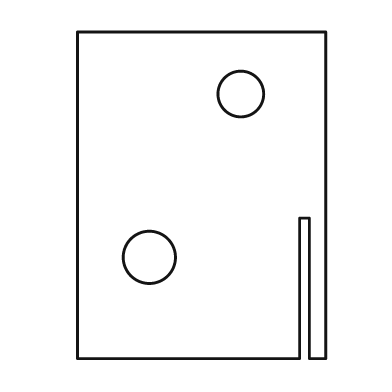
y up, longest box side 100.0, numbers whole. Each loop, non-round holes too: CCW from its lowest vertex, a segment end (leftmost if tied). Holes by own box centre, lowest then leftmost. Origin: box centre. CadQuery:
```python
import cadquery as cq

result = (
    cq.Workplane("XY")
    .moveTo(-38.0, -50.0)
    .lineTo(30.0, -50.0)
    .lineTo(30.0, -7.0)
    .lineTo(33.0, -7.0)
    .lineTo(33.0, -50.0)
    .lineTo(38.0, -50.0)
    .lineTo(38.0, 50.0)
    .lineTo(-38.0, 50.0)
    .close()
    .moveTo(-16.0, -19.0)
    .circle(8.0)
    .moveTo(12.0, 31.0)
    .circle(7.0)
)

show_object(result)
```